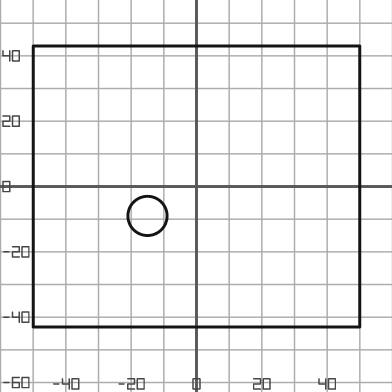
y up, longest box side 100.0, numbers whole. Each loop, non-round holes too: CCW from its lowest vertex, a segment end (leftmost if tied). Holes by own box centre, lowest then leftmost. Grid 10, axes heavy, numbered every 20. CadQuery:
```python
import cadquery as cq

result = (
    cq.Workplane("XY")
    .moveTo(-50.0, -43.0)
    .lineTo(50.0, -43.0)
    .lineTo(50.0, 43.0)
    .lineTo(-50.0, 43.0)
    .close()
    .moveTo(-15.0, -9.0)
    .circle(6.0)
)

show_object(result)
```